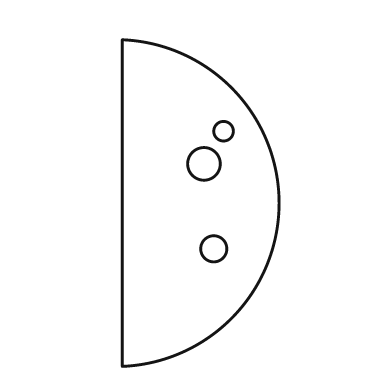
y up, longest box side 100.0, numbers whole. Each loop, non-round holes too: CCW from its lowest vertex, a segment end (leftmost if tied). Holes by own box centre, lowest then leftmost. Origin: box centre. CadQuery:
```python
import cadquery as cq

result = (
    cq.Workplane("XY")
    .moveTo(-24.0, -50.0)
    .threePointArc((24.0, 0.0), (-24.0, 50.0))
    .close()
    .moveTo(4.0, -14.0)
    .circle(4.0)
    .moveTo(1.0, 12.0)
    .circle(5.0)
    .moveTo(7.0, 22.0)
    .circle(3.0)
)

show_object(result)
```